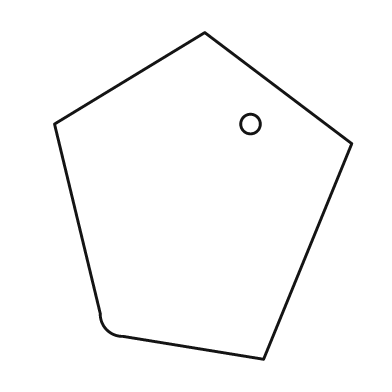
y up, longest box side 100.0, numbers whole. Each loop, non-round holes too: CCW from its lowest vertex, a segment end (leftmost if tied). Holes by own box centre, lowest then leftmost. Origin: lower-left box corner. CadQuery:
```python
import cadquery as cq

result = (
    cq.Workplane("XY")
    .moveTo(64.0, 0.0)
    .lineTo(91.0, 66.0)
    .lineTo(46.0, 100.0)
    .lineTo(0.0, 72.0)
    .lineTo(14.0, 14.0)
    .threePointArc((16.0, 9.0), (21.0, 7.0))
    .close()
    .moveTo(60.0, 72.0)
    .circle(3.0)
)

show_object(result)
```